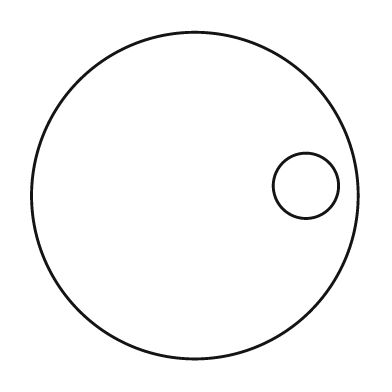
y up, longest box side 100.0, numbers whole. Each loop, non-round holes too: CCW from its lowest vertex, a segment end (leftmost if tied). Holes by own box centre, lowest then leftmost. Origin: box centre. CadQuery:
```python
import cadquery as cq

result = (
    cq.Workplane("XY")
    .moveTo(0.0, 0.0)
    .circle(50.0)
    .moveTo(34.0, 3.0)
    .circle(10.0)
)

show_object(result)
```